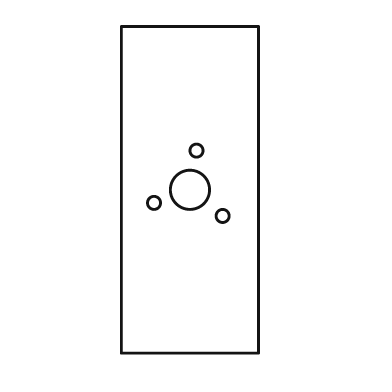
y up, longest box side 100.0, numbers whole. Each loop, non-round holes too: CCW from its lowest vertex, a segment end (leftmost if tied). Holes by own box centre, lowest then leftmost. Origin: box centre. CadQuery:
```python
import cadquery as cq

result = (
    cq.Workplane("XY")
    .moveTo(-21.0, -50.0)
    .lineTo(21.0, -50.0)
    .lineTo(21.0, 50.0)
    .lineTo(-21.0, 50.0)
    .close()
    .moveTo(10.0, -8.0)
    .circle(2.0)
    .moveTo(-11.0, -4.0)
    .circle(2.0)
    .moveTo(0.0, 0.0)
    .circle(6.0)
    .moveTo(2.0, 12.0)
    .circle(2.0)
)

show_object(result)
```